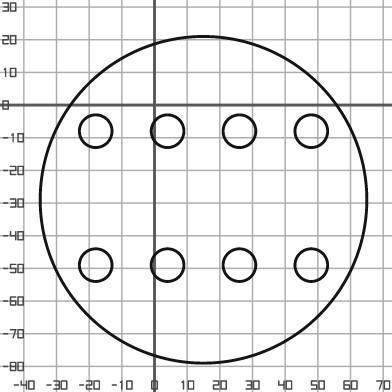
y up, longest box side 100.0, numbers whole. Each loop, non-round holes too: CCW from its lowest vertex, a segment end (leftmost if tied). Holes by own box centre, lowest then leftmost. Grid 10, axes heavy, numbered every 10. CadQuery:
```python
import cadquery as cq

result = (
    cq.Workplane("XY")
    .moveTo(15.0, -29.0)
    .circle(50.0)
    .moveTo(-18.0, -49.0)
    .circle(5.0)
    .moveTo(4.0, -49.0)
    .circle(5.0)
    .moveTo(26.0, -49.0)
    .circle(5.0)
    .moveTo(48.0, -49.0)
    .circle(5.0)
    .moveTo(-18.0, -8.0)
    .circle(5.0)
    .moveTo(4.0, -8.0)
    .circle(5.0)
    .moveTo(26.0, -8.0)
    .circle(5.0)
    .moveTo(48.0, -8.0)
    .circle(5.0)
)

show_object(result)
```